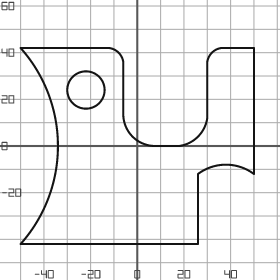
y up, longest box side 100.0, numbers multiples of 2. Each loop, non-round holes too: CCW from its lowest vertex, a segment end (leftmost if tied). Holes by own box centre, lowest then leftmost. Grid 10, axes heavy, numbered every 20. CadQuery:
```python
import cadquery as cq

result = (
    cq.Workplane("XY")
    .moveTo(-50.0, -42.0)
    .lineTo(26.0, -42.0)
    .lineTo(26.0, -12.0)
    .threePointArc((38.0, -8.0), (50.0, -12.0))
    .lineTo(50.0, 42.0)
    .lineTo(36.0, 42.0)
    .threePointArc((32.0, 40.0), (30.0, 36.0))
    .lineTo(30.0, 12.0)
    .threePointArc((26.0, 4.0), (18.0, 0.0))
    .lineTo(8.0, 0.0)
    .threePointArc((-2.0, 4.0), (-6.0, 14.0))
    .lineTo(-6.0, 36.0)
    .threePointArc((-8.0, 40.0), (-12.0, 42.0))
    .lineTo(-50.0, 42.0)
    .threePointArc((-34.0, 0.0), (-50.0, -42.0))
    .close()
    .moveTo(-22.0, 24.0)
    .circle(8.0)
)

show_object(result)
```